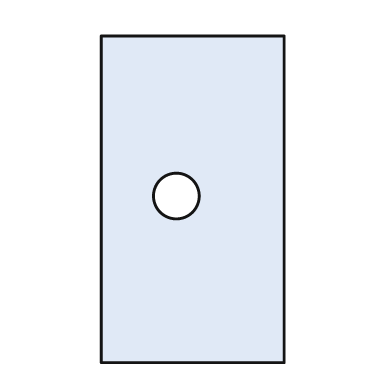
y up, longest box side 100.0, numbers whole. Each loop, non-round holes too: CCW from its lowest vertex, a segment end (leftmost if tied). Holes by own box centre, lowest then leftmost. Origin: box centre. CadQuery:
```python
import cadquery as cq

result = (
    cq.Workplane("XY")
    .moveTo(-28.0, -50.0)
    .lineTo(28.0, -50.0)
    .lineTo(28.0, 50.0)
    .lineTo(-28.0, 50.0)
    .close()
    .moveTo(-5.0, 1.0)
    .circle(7.0)
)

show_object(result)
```